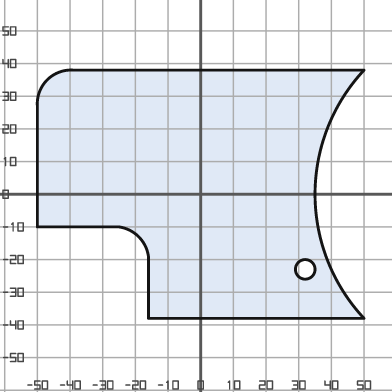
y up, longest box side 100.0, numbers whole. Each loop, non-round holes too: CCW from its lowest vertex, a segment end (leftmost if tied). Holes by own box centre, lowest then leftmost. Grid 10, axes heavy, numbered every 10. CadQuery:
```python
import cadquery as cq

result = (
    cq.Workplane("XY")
    .moveTo(-16.0, -38.0)
    .lineTo(50.0, -38.0)
    .threePointArc((35.0, 0.0), (50.0, 38.0))
    .lineTo(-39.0, 38.0)
    .threePointArc((-47.0, 35.0), (-50.0, 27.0))
    .lineTo(-50.0, -10.0)
    .lineTo(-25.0, -10.0)
    .threePointArc((-19.0, -13.0), (-16.0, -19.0))
    .close()
    .moveTo(32.0, -23.0)
    .circle(3.0)
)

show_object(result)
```